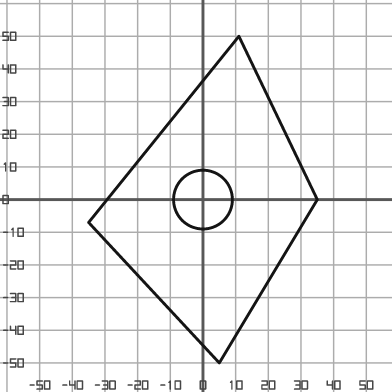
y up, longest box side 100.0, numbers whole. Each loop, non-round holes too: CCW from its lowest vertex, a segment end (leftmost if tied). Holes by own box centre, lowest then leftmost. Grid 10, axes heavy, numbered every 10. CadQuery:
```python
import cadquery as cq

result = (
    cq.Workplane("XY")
    .moveTo(5.0, -50.0)
    .lineTo(35.0, 0.0)
    .lineTo(11.0, 50.0)
    .lineTo(-35.0, -7.0)
    .close()
    .moveTo(0.0, 0.0)
    .circle(9.0)
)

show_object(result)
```